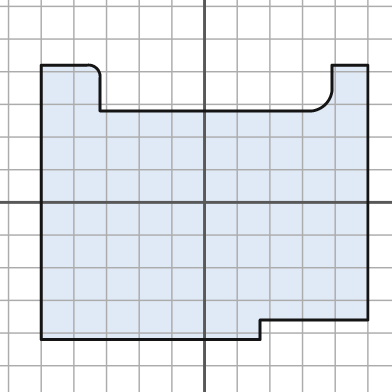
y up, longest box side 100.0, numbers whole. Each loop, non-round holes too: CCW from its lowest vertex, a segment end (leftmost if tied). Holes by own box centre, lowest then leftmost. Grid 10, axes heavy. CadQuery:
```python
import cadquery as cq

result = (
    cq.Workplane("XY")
    .moveTo(-50.0, -42.0)
    .lineTo(17.0, -42.0)
    .lineTo(17.0, -36.0)
    .lineTo(50.0, -36.0)
    .lineTo(50.0, 42.0)
    .lineTo(39.0, 42.0)
    .lineTo(39.0, 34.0)
    .threePointArc((37.0, 30.0), (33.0, 28.0))
    .lineTo(-32.0, 28.0)
    .lineTo(-32.0, 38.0)
    .threePointArc((-33.0, 41.0), (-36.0, 42.0))
    .lineTo(-50.0, 42.0)
    .close()
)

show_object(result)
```